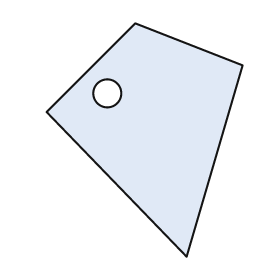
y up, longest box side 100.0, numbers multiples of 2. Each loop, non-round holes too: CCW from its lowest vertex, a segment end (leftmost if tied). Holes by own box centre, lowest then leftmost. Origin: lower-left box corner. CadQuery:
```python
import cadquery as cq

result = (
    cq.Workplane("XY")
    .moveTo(60.0, 0.0)
    .lineTo(84.0, 82.0)
    .lineTo(38.0, 100.0)
    .lineTo(0.0, 62.0)
    .close()
    .moveTo(26.0, 70.0)
    .circle(6.0)
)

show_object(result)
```